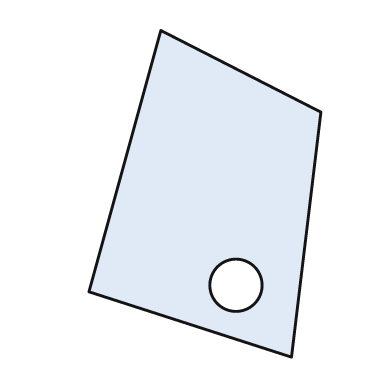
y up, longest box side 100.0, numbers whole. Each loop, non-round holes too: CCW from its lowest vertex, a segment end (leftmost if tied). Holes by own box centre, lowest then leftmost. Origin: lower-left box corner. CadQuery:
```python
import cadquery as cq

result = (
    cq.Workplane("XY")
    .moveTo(62.0, 0.0)
    .lineTo(71.0, 75.0)
    .lineTo(22.0, 100.0)
    .lineTo(0.0, 20.0)
    .close()
    .moveTo(45.0, 22.0)
    .circle(8.0)
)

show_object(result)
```